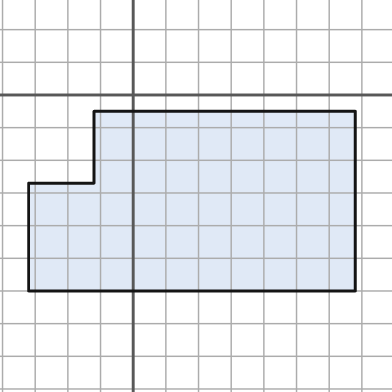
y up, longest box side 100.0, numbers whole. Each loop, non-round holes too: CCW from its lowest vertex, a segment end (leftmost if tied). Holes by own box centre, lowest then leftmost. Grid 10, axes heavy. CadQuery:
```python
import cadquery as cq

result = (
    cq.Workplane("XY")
    .moveTo(-32.0, -60.0)
    .lineTo(68.0, -60.0)
    .lineTo(68.0, -5.0)
    .lineTo(-12.0, -5.0)
    .lineTo(-12.0, -27.0)
    .lineTo(-32.0, -27.0)
    .close()
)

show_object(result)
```